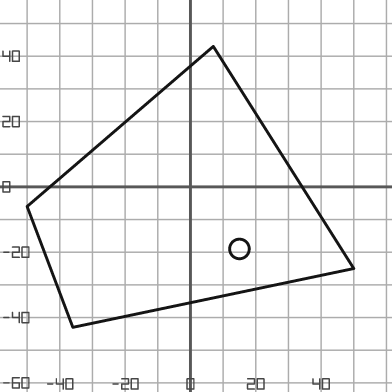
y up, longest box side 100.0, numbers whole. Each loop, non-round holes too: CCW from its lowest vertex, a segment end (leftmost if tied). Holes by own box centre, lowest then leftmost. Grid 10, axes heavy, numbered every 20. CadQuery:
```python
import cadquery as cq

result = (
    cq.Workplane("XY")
    .moveTo(-36.0, -43.0)
    .lineTo(50.0, -25.0)
    .lineTo(7.0, 43.0)
    .lineTo(-50.0, -6.0)
    .close()
    .moveTo(15.0, -19.0)
    .circle(3.0)
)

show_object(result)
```